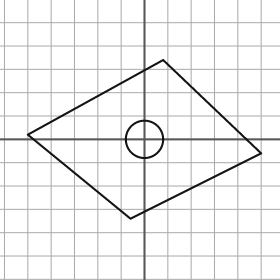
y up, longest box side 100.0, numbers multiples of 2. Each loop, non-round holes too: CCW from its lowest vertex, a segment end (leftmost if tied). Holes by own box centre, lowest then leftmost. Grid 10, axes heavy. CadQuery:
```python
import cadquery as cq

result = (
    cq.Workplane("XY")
    .moveTo(-6.0, -34.0)
    .lineTo(50.0, -6.0)
    .lineTo(8.0, 34.0)
    .lineTo(-50.0, 2.0)
    .close()
    .moveTo(0.0, 0.0)
    .circle(8.0)
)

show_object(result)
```